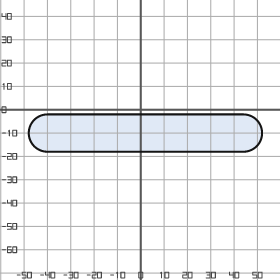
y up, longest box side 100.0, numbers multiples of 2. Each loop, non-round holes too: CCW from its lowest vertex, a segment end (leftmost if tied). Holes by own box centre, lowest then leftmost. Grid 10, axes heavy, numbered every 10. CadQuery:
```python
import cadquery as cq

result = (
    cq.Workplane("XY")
    .moveTo(-40.0, -18.0)
    .lineTo(44.0, -18.0)
    .threePointArc((52.0, -10.0), (44.0, -2.0))
    .lineTo(-40.0, -2.0)
    .threePointArc((-48.0, -10.0), (-40.0, -18.0))
    .close()
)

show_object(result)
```